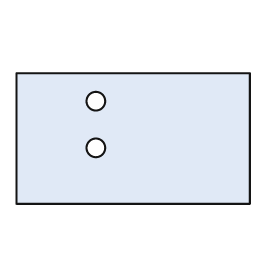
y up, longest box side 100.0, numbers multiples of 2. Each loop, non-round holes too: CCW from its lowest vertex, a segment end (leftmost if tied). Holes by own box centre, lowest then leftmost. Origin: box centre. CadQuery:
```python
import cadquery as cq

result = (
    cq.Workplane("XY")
    .moveTo(-50.0, -28.0)
    .lineTo(50.0, -28.0)
    .lineTo(50.0, 28.0)
    .lineTo(-50.0, 28.0)
    .close()
    .moveTo(-16.0, -4.0)
    .circle(4.0)
    .moveTo(-16.0, 16.0)
    .circle(4.0)
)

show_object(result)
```